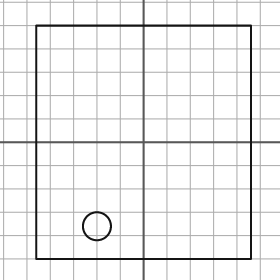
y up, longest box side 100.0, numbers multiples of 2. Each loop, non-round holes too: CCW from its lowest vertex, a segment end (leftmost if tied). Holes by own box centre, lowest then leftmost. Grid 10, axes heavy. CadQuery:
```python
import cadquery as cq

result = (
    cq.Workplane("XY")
    .moveTo(-46.0, -50.0)
    .lineTo(46.0, -50.0)
    .lineTo(46.0, 50.0)
    .lineTo(-46.0, 50.0)
    .close()
    .moveTo(-20.0, -36.0)
    .circle(6.0)
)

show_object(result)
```